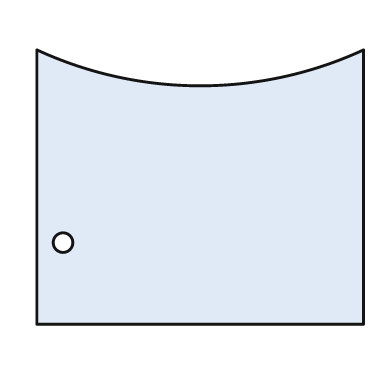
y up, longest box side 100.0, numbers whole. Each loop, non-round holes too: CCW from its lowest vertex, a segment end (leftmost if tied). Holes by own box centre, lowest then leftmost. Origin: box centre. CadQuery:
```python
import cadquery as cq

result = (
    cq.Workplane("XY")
    .moveTo(-50.0, -42.0)
    .lineTo(50.0, -42.0)
    .lineTo(50.0, 42.0)
    .threePointArc((0.0, 31.0), (-50.0, 42.0))
    .close()
    .moveTo(-42.0, -17.0)
    .circle(3.0)
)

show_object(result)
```